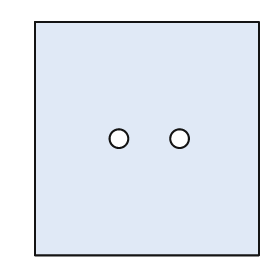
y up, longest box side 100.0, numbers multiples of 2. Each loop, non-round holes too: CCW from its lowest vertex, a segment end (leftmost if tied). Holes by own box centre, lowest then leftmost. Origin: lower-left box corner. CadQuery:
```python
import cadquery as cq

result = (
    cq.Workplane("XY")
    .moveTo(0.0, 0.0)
    .lineTo(96.0, 0.0)
    .lineTo(96.0, 100.0)
    .lineTo(0.0, 100.0)
    .close()
    .moveTo(36.0, 50.0)
    .circle(4.0)
    .moveTo(62.0, 50.0)
    .circle(4.0)
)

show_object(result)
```